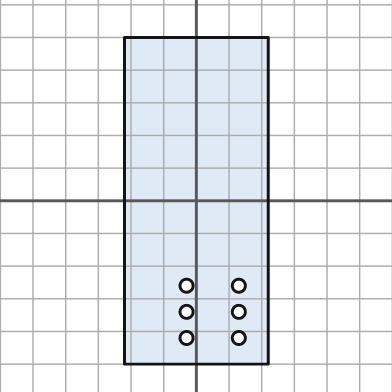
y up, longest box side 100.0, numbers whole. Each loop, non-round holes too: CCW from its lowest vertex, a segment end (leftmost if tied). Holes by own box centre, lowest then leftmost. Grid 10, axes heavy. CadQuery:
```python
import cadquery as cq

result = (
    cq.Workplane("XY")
    .moveTo(-22.0, -50.0)
    .lineTo(22.0, -50.0)
    .lineTo(22.0, 50.0)
    .lineTo(-22.0, 50.0)
    .close()
    .moveTo(-3.0, -42.0)
    .circle(2.0)
    .moveTo(13.0, -42.0)
    .circle(2.0)
    .moveTo(-3.0, -34.0)
    .circle(2.0)
    .moveTo(13.0, -34.0)
    .circle(2.0)
    .moveTo(-3.0, -26.0)
    .circle(2.0)
    .moveTo(13.0, -26.0)
    .circle(2.0)
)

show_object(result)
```